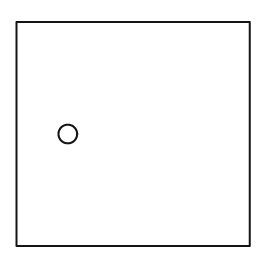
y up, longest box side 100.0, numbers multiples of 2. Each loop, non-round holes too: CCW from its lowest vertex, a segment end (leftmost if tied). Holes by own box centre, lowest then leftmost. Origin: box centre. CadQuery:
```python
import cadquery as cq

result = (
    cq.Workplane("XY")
    .moveTo(-50.0, -48.0)
    .lineTo(50.0, -48.0)
    .lineTo(50.0, 48.0)
    .lineTo(-50.0, 48.0)
    .close()
    .moveTo(-28.0, 0.0)
    .circle(4.0)
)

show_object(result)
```